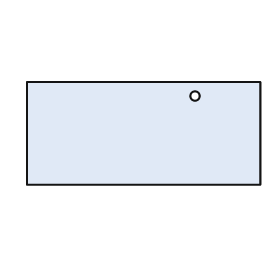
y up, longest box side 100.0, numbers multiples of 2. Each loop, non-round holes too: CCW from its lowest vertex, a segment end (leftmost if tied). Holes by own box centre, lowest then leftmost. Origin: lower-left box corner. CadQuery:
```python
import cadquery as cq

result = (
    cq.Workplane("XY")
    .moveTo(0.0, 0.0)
    .lineTo(100.0, 0.0)
    .lineTo(100.0, 44.0)
    .lineTo(0.0, 44.0)
    .close()
    .moveTo(72.0, 38.0)
    .circle(2.0)
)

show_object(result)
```